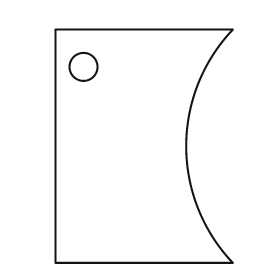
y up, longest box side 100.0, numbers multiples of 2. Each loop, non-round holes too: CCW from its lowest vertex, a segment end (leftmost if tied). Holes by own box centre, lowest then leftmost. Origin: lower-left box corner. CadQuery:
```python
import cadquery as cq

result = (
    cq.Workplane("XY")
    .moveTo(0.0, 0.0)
    .lineTo(76.0, 0.0)
    .threePointArc((56.0, 50.0), (76.0, 100.0))
    .lineTo(0.0, 100.0)
    .close()
    .moveTo(12.0, 84.0)
    .circle(6.0)
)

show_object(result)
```